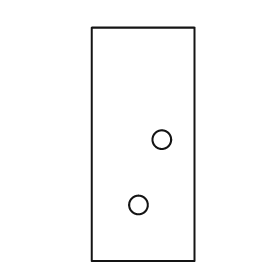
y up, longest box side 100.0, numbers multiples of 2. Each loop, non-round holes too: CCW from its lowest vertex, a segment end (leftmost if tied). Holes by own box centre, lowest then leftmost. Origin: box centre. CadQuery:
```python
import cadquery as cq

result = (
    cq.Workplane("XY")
    .moveTo(-22.0, -50.0)
    .lineTo(22.0, -50.0)
    .lineTo(22.0, 50.0)
    .lineTo(-22.0, 50.0)
    .close()
    .moveTo(-2.0, -26.0)
    .circle(4.0)
    .moveTo(8.0, 2.0)
    .circle(4.0)
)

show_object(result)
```